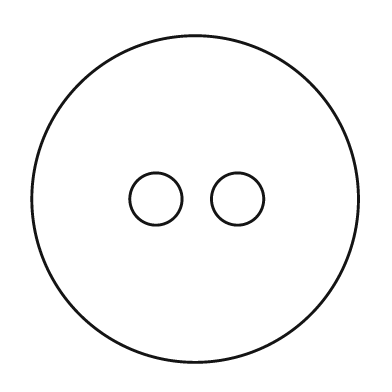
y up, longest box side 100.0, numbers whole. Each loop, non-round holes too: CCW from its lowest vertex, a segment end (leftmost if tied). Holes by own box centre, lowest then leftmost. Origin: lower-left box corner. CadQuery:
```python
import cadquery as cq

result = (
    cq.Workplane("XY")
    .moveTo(50.0, 50.0)
    .circle(50.0)
    .moveTo(38.0, 50.0)
    .circle(8.0)
    .moveTo(63.0, 50.0)
    .circle(8.0)
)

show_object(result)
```